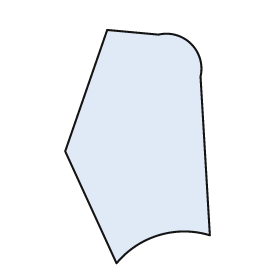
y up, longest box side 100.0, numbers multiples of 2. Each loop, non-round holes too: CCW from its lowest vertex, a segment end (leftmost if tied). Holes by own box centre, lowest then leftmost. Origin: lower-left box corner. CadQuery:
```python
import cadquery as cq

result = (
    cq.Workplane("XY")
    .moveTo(22.0, 0.0)
    .threePointArc((40.0, 12.0), (62.0, 12.0))
    .lineTo(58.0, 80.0)
    .threePointArc((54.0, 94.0), (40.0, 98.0))
    .lineTo(18.0, 100.0)
    .lineTo(0.0, 48.0)
    .close()
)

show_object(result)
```